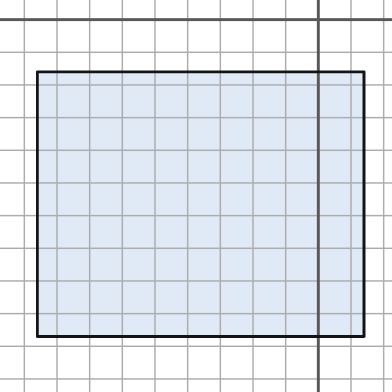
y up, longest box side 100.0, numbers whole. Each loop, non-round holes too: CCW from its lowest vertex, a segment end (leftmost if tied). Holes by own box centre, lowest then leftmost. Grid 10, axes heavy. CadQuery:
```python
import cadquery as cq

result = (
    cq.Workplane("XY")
    .moveTo(-86.0, -97.0)
    .lineTo(14.0, -97.0)
    .lineTo(14.0, -16.0)
    .lineTo(-86.0, -16.0)
    .close()
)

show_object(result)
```